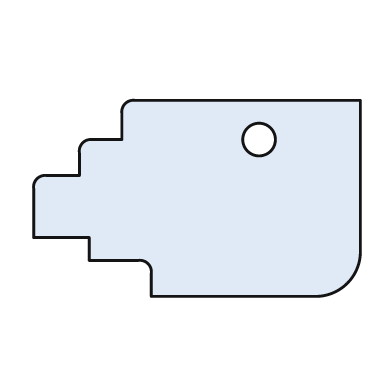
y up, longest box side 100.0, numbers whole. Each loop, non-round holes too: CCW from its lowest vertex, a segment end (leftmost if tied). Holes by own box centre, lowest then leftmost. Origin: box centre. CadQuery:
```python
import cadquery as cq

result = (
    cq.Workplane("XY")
    .moveTo(-14.0, -30.0)
    .lineTo(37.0, -30.0)
    .threePointArc((46.0, -26.0), (50.0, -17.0))
    .lineTo(50.0, 30.0)
    .lineTo(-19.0, 30.0)
    .threePointArc((-22.0, 29.0), (-23.0, 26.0))
    .lineTo(-23.0, 18.0)
    .lineTo(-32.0, 18.0)
    .threePointArc((-35.0, 17.0), (-36.0, 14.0))
    .lineTo(-36.0, 7.0)
    .lineTo(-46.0, 7.0)
    .threePointArc((-49.0, 6.0), (-50.0, 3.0))
    .lineTo(-50.0, -12.0)
    .lineTo(-33.0, -12.0)
    .lineTo(-33.0, -19.0)
    .lineTo(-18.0, -19.0)
    .threePointArc((-15.0, -20.0), (-14.0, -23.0))
    .close()
    .moveTo(19.0, 18.0)
    .circle(5.0)
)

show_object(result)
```